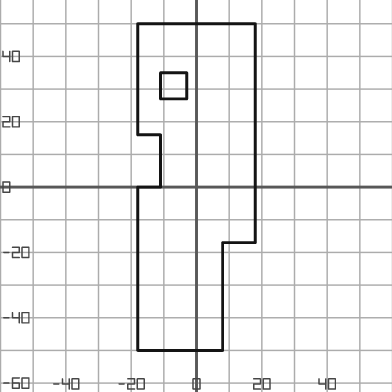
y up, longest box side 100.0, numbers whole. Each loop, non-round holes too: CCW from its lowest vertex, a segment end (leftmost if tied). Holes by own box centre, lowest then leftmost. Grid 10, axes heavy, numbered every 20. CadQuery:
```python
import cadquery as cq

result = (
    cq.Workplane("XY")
    .moveTo(-18.0, -50.0)
    .lineTo(8.0, -50.0)
    .lineTo(8.0, -17.0)
    .lineTo(18.0, -17.0)
    .lineTo(18.0, 50.0)
    .lineTo(-18.0, 50.0)
    .lineTo(-18.0, 16.0)
    .lineTo(-11.0, 16.0)
    .lineTo(-11.0, 0.0)
    .lineTo(-18.0, 0.0)
    .close()
    .moveTo(-11.0, 27.0)
    .lineTo(-3.0, 27.0)
    .lineTo(-3.0, 35.0)
    .lineTo(-11.0, 35.0)
    .close()
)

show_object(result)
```